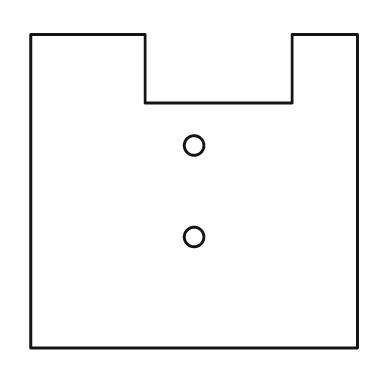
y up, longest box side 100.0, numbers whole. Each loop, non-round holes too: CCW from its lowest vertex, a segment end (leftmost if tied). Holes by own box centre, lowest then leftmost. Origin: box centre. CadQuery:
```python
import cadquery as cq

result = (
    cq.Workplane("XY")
    .moveTo(-50.0, -48.0)
    .lineTo(50.0, -48.0)
    .lineTo(50.0, 48.0)
    .lineTo(30.0, 48.0)
    .lineTo(30.0, 27.0)
    .lineTo(-15.0, 27.0)
    .lineTo(-15.0, 48.0)
    .lineTo(-50.0, 48.0)
    .close()
    .moveTo(0.0, -14.0)
    .circle(3.0)
    .moveTo(0.0, 14.0)
    .circle(3.0)
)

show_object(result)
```